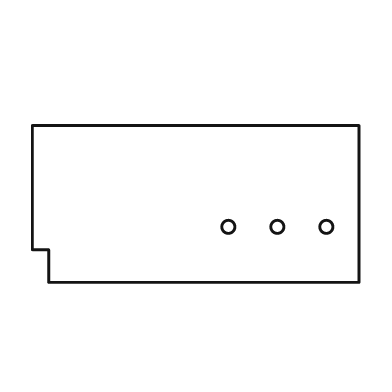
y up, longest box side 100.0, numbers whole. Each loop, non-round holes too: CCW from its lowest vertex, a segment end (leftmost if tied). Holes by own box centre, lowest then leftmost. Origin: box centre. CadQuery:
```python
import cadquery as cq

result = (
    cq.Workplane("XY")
    .moveTo(-45.0, -24.0)
    .lineTo(50.0, -24.0)
    .lineTo(50.0, 24.0)
    .lineTo(-50.0, 24.0)
    .lineTo(-50.0, -14.0)
    .lineTo(-45.0, -14.0)
    .close()
    .moveTo(10.0, -7.0)
    .circle(2.0)
    .moveTo(25.0, -7.0)
    .circle(2.0)
    .moveTo(40.0, -7.0)
    .circle(2.0)
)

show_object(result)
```